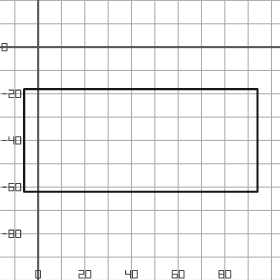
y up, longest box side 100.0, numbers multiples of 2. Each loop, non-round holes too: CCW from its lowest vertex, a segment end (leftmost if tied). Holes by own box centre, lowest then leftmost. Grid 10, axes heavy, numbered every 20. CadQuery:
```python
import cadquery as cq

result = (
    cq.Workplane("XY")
    .moveTo(-6.0, -62.0)
    .lineTo(94.0, -62.0)
    .lineTo(94.0, -18.0)
    .lineTo(-6.0, -18.0)
    .close()
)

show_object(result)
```